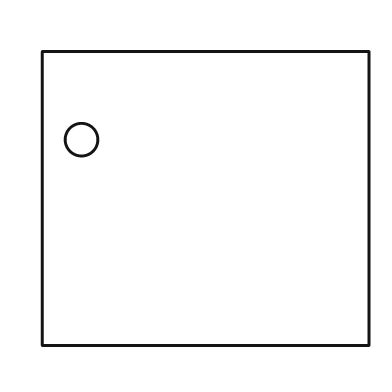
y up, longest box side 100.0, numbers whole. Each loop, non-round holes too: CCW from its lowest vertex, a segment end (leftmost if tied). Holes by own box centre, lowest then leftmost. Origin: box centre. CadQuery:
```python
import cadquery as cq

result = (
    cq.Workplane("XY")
    .moveTo(-50.0, -45.0)
    .lineTo(50.0, -45.0)
    .lineTo(50.0, 45.0)
    .lineTo(-50.0, 45.0)
    .close()
    .moveTo(-38.0, 18.0)
    .circle(5.0)
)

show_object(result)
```